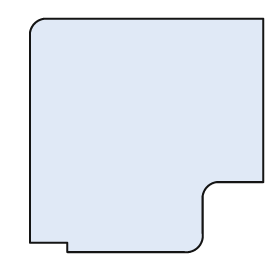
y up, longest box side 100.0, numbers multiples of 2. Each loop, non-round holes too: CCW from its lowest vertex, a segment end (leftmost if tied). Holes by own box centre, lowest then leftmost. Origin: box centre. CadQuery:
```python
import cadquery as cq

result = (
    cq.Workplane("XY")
    .moveTo(-34.0, -50.0)
    .lineTo(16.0, -50.0)
    .threePointArc((22.0, -48.0), (24.0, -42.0))
    .lineTo(24.0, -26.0)
    .threePointArc((26.0, -22.0), (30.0, -20.0))
    .lineTo(50.0, -20.0)
    .lineTo(50.0, 50.0)
    .lineTo(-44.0, 50.0)
    .threePointArc((-48.0, 48.0), (-50.0, 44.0))
    .lineTo(-50.0, -46.0)
    .lineTo(-34.0, -46.0)
    .close()
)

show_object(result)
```